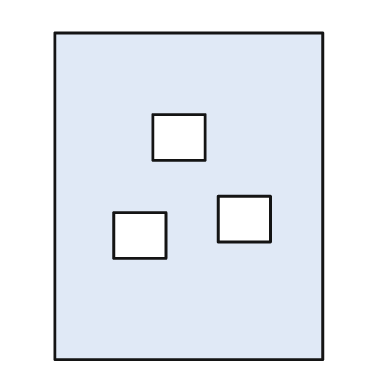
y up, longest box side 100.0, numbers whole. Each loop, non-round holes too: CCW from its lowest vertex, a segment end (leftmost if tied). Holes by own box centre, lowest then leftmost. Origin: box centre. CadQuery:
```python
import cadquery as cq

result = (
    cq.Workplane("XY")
    .moveTo(-41.0, -50.0)
    .lineTo(41.0, -50.0)
    .lineTo(41.0, 50.0)
    .lineTo(-41.0, 50.0)
    .close()
    .moveTo(-23.0, -19.0)
    .lineTo(-7.0, -19.0)
    .lineTo(-7.0, -5.0)
    .lineTo(-23.0, -5.0)
    .close()
    .moveTo(9.0, -14.0)
    .lineTo(25.0, -14.0)
    .lineTo(25.0, 0.0)
    .lineTo(9.0, 0.0)
    .close()
    .moveTo(-11.0, 11.0)
    .lineTo(5.0, 11.0)
    .lineTo(5.0, 25.0)
    .lineTo(-11.0, 25.0)
    .close()
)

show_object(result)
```